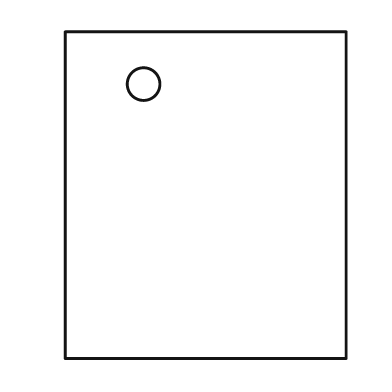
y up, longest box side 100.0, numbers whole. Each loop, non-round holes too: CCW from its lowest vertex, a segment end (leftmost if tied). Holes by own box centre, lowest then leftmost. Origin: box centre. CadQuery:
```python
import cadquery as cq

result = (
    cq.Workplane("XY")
    .moveTo(-43.0, -50.0)
    .lineTo(43.0, -50.0)
    .lineTo(43.0, 50.0)
    .lineTo(-43.0, 50.0)
    .close()
    .moveTo(-19.0, 34.0)
    .circle(5.0)
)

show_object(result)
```